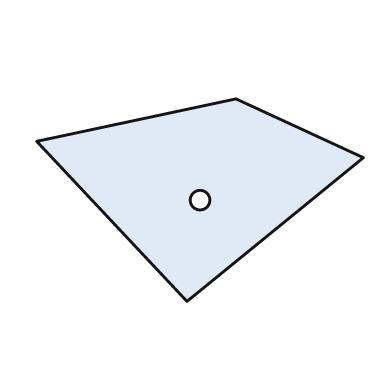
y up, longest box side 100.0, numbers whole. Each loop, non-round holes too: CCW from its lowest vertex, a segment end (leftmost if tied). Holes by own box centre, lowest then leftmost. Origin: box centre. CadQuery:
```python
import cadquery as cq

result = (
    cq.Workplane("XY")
    .moveTo(-4.0, -31.0)
    .lineTo(50.0, 13.0)
    .lineTo(11.0, 31.0)
    .lineTo(-50.0, 18.0)
    .close()
    .moveTo(0.0, 0.0)
    .circle(3.0)
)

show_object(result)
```